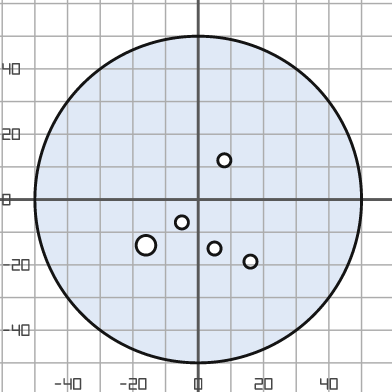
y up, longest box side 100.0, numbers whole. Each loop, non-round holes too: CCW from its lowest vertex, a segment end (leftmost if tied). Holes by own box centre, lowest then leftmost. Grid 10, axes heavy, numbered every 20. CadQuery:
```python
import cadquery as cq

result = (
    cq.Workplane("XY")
    .moveTo(0.0, 0.0)
    .circle(50.0)
    .moveTo(16.0, -19.0)
    .circle(2.0)
    .moveTo(5.0, -15.0)
    .circle(2.0)
    .moveTo(-16.0, -14.0)
    .circle(3.0)
    .moveTo(-5.0, -7.0)
    .circle(2.0)
    .moveTo(8.0, 12.0)
    .circle(2.0)
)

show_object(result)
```